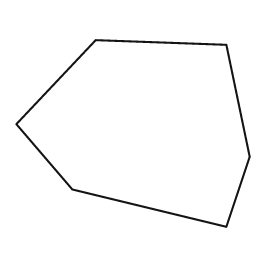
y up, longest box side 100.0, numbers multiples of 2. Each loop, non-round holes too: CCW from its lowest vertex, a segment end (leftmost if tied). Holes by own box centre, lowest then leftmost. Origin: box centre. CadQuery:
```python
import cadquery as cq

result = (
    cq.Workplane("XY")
    .moveTo(40.0, -40.0)
    .lineTo(50.0, -10.0)
    .lineTo(40.0, 38.0)
    .lineTo(-16.0, 40.0)
    .lineTo(-50.0, 4.0)
    .lineTo(-26.0, -24.0)
    .close()
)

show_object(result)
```